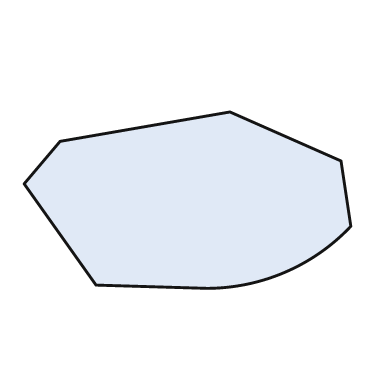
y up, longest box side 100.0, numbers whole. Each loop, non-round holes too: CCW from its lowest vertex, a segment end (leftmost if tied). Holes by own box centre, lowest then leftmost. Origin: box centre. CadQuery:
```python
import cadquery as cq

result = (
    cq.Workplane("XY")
    .moveTo(6.0, -27.0)
    .threePointArc((30.0, -22.0), (50.0, -8.0))
    .lineTo(47.0, 12.0)
    .lineTo(13.0, 27.0)
    .lineTo(-39.0, 18.0)
    .lineTo(-50.0, 5.0)
    .lineTo(-28.0, -26.0)
    .close()
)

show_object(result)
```